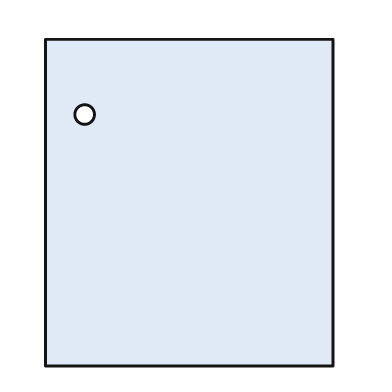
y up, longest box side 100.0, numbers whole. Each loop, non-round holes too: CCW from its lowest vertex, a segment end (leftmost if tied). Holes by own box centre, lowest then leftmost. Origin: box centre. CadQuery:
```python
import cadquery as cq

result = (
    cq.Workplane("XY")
    .moveTo(-44.0, -50.0)
    .lineTo(44.0, -50.0)
    .lineTo(44.0, 50.0)
    .lineTo(-44.0, 50.0)
    .close()
    .moveTo(-32.0, 27.0)
    .circle(3.0)
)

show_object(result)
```